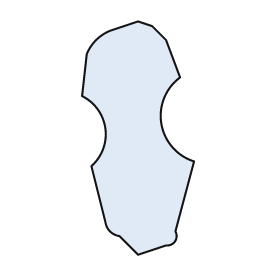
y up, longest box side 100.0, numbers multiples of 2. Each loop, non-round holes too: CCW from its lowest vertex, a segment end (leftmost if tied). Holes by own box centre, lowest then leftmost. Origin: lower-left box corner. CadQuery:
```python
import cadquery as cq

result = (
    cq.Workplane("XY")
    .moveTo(24.0, 0.0)
    .lineTo(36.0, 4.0)
    .threePointArc((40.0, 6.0), (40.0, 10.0))
    .lineTo(48.0, 40.0)
    .threePointArc((34.0, 56.0), (42.0, 76.0))
    .lineTo(36.0, 92.0)
    .lineTo(30.0, 98.0)
    .lineTo(24.0, 100.0)
    .lineTo(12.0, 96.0)
    .threePointArc((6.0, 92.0), (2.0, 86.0))
    .lineTo(0.0, 68.0)
    .threePointArc((10.0, 54.0), (4.0, 38.0))
    .lineTo(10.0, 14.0)
    .threePointArc((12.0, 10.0), (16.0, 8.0))
    .close()
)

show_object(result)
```